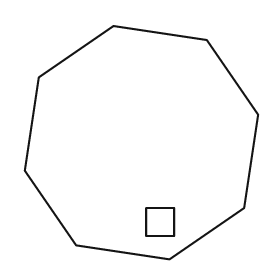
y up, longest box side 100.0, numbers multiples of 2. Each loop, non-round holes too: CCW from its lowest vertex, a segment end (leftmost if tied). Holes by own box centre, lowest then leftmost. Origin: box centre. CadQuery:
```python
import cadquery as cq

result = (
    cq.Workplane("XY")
    .moveTo(12.0, -50.0)
    .lineTo(44.0, -28.0)
    .lineTo(50.0, 12.0)
    .lineTo(28.0, 44.0)
    .lineTo(-12.0, 50.0)
    .lineTo(-44.0, 28.0)
    .lineTo(-50.0, -12.0)
    .lineTo(-28.0, -44.0)
    .close()
    .moveTo(2.0, -40.0)
    .lineTo(14.0, -40.0)
    .lineTo(14.0, -28.0)
    .lineTo(2.0, -28.0)
    .close()
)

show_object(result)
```